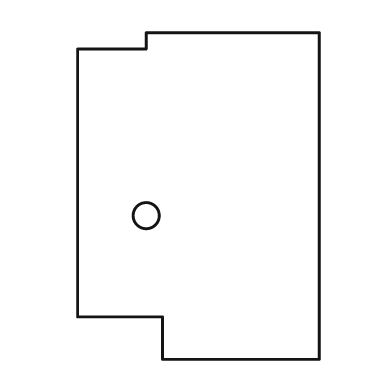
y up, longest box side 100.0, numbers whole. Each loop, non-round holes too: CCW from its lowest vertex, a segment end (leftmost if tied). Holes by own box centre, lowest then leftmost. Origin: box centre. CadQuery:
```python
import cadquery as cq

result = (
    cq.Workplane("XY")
    .moveTo(-11.0, -50.0)
    .lineTo(37.0, -50.0)
    .lineTo(37.0, 50.0)
    .lineTo(-16.0, 50.0)
    .lineTo(-16.0, 45.0)
    .lineTo(-37.0, 45.0)
    .lineTo(-37.0, -37.0)
    .lineTo(-11.0, -37.0)
    .close()
    .moveTo(-16.0, -6.0)
    .circle(4.0)
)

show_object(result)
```